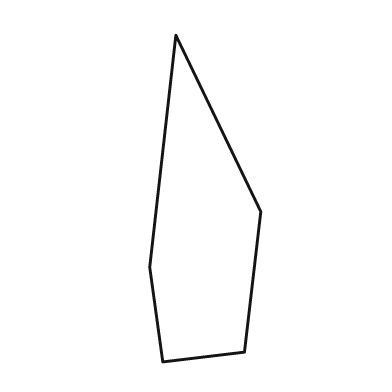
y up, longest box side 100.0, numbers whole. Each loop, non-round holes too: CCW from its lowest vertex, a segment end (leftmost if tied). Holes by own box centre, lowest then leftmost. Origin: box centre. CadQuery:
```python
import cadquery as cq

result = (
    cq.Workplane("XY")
    .moveTo(-13.0, -50.0)
    .lineTo(12.0, -47.0)
    .lineTo(17.0, -4.0)
    .lineTo(-9.0, 50.0)
    .lineTo(-17.0, -21.0)
    .close()
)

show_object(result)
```